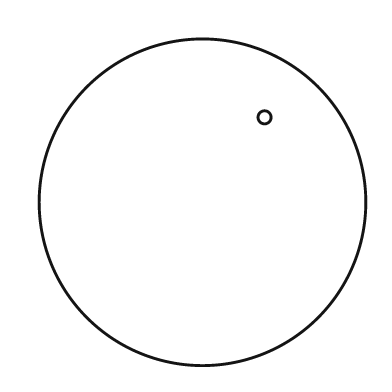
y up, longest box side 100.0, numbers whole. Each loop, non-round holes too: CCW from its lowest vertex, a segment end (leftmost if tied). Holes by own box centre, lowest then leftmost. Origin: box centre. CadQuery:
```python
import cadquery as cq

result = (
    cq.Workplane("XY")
    .moveTo(0.0, 0.0)
    .circle(50.0)
    .moveTo(19.0, 26.0)
    .circle(2.0)
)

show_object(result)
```